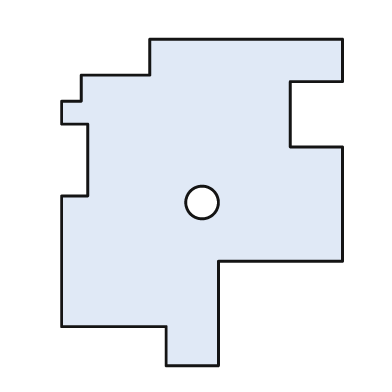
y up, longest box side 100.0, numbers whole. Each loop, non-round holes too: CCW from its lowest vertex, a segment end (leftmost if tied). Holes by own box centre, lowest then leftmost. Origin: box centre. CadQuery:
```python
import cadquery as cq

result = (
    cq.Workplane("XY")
    .moveTo(-11.0, -50.0)
    .lineTo(5.0, -50.0)
    .lineTo(5.0, -18.0)
    .lineTo(43.0, -18.0)
    .lineTo(43.0, 17.0)
    .lineTo(27.0, 17.0)
    .lineTo(27.0, 37.0)
    .lineTo(43.0, 37.0)
    .lineTo(43.0, 50.0)
    .lineTo(-16.0, 50.0)
    .lineTo(-16.0, 39.0)
    .lineTo(-37.0, 39.0)
    .lineTo(-37.0, 31.0)
    .lineTo(-43.0, 31.0)
    .lineTo(-43.0, 24.0)
    .lineTo(-35.0, 24.0)
    .lineTo(-35.0, 2.0)
    .lineTo(-43.0, 2.0)
    .lineTo(-43.0, -38.0)
    .lineTo(-11.0, -38.0)
    .close()
    .moveTo(0.0, 0.0)
    .circle(5.0)
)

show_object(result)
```